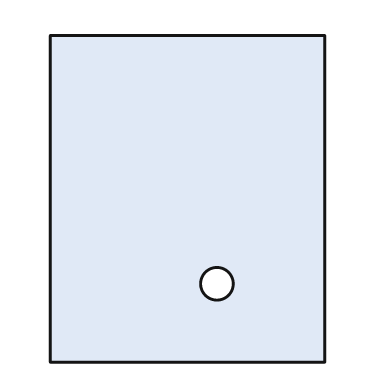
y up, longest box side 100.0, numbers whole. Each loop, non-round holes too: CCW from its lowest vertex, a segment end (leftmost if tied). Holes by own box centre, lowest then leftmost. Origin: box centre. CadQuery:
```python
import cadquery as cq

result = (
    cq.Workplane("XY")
    .moveTo(-42.0, -50.0)
    .lineTo(42.0, -50.0)
    .lineTo(42.0, 50.0)
    .lineTo(-42.0, 50.0)
    .close()
    .moveTo(9.0, -26.0)
    .circle(5.0)
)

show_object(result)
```